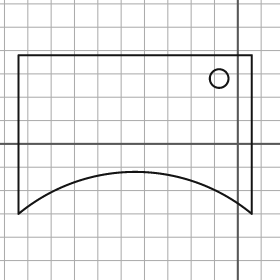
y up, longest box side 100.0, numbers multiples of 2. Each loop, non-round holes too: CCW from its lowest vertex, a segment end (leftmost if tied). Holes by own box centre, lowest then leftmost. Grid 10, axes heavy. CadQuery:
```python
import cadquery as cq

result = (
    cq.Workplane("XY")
    .moveTo(-94.0, -30.0)
    .threePointArc((-44.0, -12.0), (6.0, -30.0))
    .lineTo(6.0, 38.0)
    .lineTo(-94.0, 38.0)
    .close()
    .moveTo(-8.0, 28.0)
    .circle(4.0)
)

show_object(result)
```